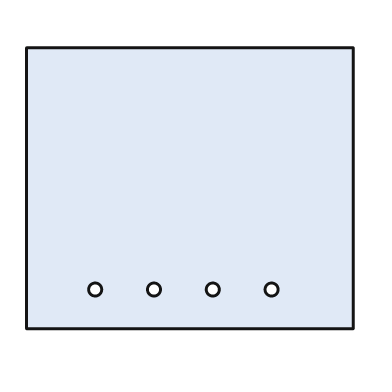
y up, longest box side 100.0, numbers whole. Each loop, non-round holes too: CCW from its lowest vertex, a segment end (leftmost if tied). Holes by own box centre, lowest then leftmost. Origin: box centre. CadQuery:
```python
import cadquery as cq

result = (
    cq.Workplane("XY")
    .moveTo(-50.0, -43.0)
    .lineTo(50.0, -43.0)
    .lineTo(50.0, 43.0)
    .lineTo(-50.0, 43.0)
    .close()
    .moveTo(-29.0, -31.0)
    .circle(2.0)
    .moveTo(-11.0, -31.0)
    .circle(2.0)
    .moveTo(7.0, -31.0)
    .circle(2.0)
    .moveTo(25.0, -31.0)
    .circle(2.0)
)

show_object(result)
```